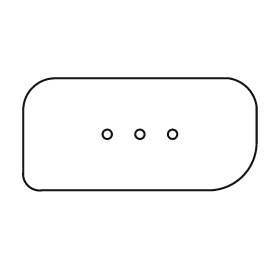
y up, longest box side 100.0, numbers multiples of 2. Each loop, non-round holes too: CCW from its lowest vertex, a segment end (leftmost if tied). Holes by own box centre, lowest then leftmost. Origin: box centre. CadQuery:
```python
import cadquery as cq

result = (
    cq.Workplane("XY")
    .moveTo(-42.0, -24.0)
    .lineTo(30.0, -24.0)
    .threePointArc((44.0, -18.0), (50.0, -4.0))
    .lineTo(50.0, 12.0)
    .threePointArc((46.0, 20.0), (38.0, 24.0))
    .lineTo(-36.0, 24.0)
    .threePointArc((-46.0, 20.0), (-50.0, 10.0))
    .lineTo(-50.0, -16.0)
    .threePointArc((-48.0, -22.0), (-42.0, -24.0))
    .close()
    .moveTo(-14.0, 0.0)
    .circle(2.0)
    .moveTo(0.0, 0.0)
    .circle(2.0)
    .moveTo(14.0, 0.0)
    .circle(2.0)
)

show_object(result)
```